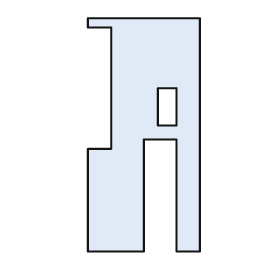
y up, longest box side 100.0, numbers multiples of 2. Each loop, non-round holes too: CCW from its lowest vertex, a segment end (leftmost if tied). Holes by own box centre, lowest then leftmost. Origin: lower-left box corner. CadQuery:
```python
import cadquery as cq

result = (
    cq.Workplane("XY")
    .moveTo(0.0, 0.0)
    .lineTo(24.0, 0.0)
    .lineTo(24.0, 48.0)
    .lineTo(38.0, 48.0)
    .lineTo(38.0, 0.0)
    .lineTo(48.0, 0.0)
    .lineTo(48.0, 100.0)
    .lineTo(0.0, 100.0)
    .lineTo(0.0, 96.0)
    .lineTo(10.0, 96.0)
    .lineTo(10.0, 44.0)
    .lineTo(0.0, 44.0)
    .close()
    .moveTo(30.0, 54.0)
    .lineTo(38.0, 54.0)
    .lineTo(38.0, 70.0)
    .lineTo(30.0, 70.0)
    .close()
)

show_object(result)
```